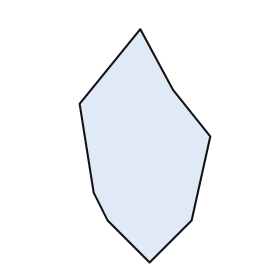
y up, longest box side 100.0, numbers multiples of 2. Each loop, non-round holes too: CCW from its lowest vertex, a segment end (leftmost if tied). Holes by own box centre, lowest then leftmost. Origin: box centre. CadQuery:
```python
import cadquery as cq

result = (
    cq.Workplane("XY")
    .moveTo(2.0, -50.0)
    .lineTo(20.0, -32.0)
    .lineTo(28.0, 4.0)
    .lineTo(12.0, 24.0)
    .lineTo(-2.0, 50.0)
    .lineTo(-28.0, 18.0)
    .lineTo(-22.0, -20.0)
    .lineTo(-16.0, -32.0)
    .close()
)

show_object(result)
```